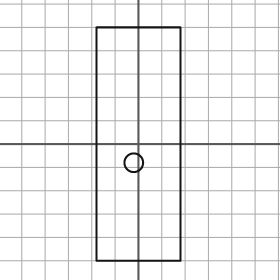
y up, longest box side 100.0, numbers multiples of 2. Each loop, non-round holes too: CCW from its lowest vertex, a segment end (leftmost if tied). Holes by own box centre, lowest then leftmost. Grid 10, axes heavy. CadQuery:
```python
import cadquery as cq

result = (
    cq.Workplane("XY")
    .moveTo(-18.0, -50.0)
    .lineTo(18.0, -50.0)
    .lineTo(18.0, 50.0)
    .lineTo(-18.0, 50.0)
    .close()
    .moveTo(-2.0, -8.0)
    .circle(4.0)
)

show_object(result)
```